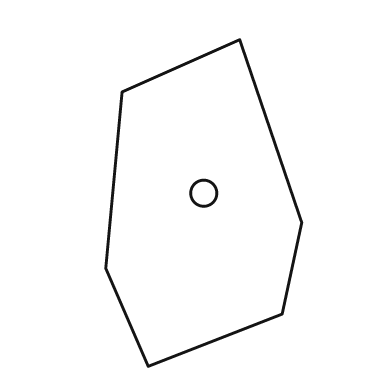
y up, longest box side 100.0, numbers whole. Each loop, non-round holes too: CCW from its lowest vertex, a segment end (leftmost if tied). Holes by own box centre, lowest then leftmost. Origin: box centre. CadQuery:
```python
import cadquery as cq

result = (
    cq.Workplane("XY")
    .moveTo(-17.0, -50.0)
    .lineTo(24.0, -34.0)
    .lineTo(30.0, -6.0)
    .lineTo(11.0, 50.0)
    .lineTo(-25.0, 34.0)
    .lineTo(-30.0, -20.0)
    .close()
    .moveTo(0.0, 3.0)
    .circle(4.0)
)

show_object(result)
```